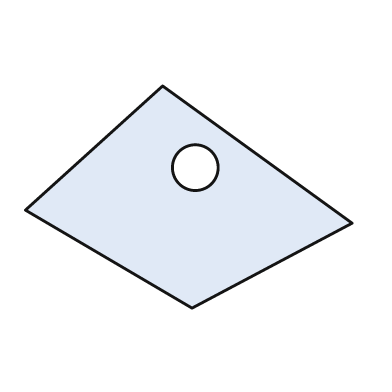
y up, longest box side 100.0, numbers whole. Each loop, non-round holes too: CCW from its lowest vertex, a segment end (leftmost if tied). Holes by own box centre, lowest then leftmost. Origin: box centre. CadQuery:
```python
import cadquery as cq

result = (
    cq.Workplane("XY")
    .moveTo(1.0, -34.0)
    .lineTo(50.0, -8.0)
    .lineTo(-8.0, 34.0)
    .lineTo(-50.0, -4.0)
    .close()
    .moveTo(2.0, 9.0)
    .circle(7.0)
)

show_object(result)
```